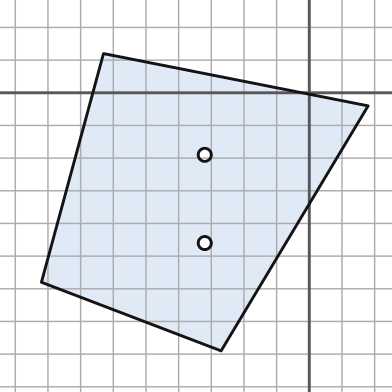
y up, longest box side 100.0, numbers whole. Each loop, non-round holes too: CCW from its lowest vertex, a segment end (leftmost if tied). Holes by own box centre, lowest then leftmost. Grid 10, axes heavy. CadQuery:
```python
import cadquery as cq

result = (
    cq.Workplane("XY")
    .moveTo(-27.0, -79.0)
    .lineTo(18.0, -4.0)
    .lineTo(-63.0, 12.0)
    .lineTo(-82.0, -58.0)
    .close()
    .moveTo(-32.0, -46.0)
    .circle(2.0)
    .moveTo(-32.0, -19.0)
    .circle(2.0)
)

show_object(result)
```